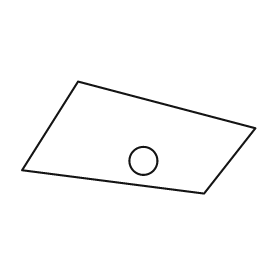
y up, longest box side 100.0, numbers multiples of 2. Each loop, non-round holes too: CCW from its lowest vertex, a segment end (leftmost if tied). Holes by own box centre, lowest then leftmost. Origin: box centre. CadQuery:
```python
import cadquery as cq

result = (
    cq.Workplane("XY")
    .moveTo(28.0, -24.0)
    .lineTo(50.0, 4.0)
    .lineTo(-26.0, 24.0)
    .lineTo(-50.0, -14.0)
    .close()
    .moveTo(2.0, -10.0)
    .circle(6.0)
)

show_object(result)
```